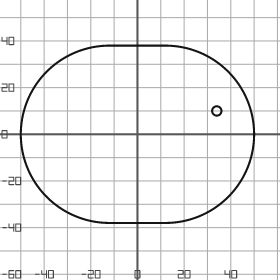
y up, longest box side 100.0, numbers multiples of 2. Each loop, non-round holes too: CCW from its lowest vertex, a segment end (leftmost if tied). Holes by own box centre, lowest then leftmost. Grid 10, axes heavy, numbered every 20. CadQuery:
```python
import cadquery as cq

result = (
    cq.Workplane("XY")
    .moveTo(-12.0, -38.0)
    .lineTo(12.0, -38.0)
    .threePointArc((50.0, 0.0), (12.0, 38.0))
    .lineTo(-12.0, 38.0)
    .threePointArc((-50.0, 0.0), (-12.0, -38.0))
    .close()
    .moveTo(34.0, 10.0)
    .circle(2.0)
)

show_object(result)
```